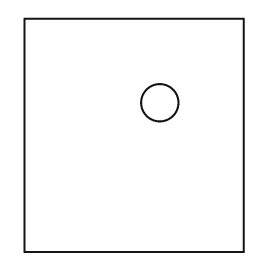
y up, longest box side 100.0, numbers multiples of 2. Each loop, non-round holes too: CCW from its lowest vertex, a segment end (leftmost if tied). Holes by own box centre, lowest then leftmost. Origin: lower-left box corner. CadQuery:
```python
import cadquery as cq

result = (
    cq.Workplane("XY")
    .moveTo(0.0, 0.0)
    .lineTo(94.0, 0.0)
    .lineTo(94.0, 100.0)
    .lineTo(0.0, 100.0)
    .close()
    .moveTo(58.0, 64.0)
    .circle(8.0)
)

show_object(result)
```